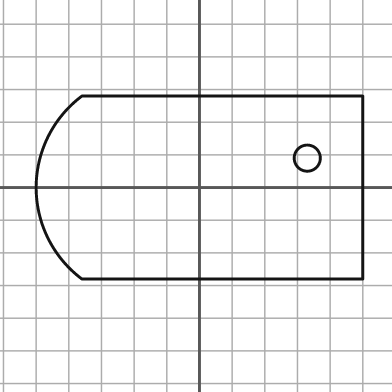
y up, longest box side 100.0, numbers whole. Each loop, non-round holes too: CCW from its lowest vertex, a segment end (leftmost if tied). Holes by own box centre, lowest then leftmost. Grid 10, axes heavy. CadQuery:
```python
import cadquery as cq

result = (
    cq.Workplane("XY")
    .moveTo(-36.0, -28.0)
    .lineTo(50.0, -28.0)
    .lineTo(50.0, 28.0)
    .lineTo(-36.0, 28.0)
    .threePointArc((-50.0, 0.0), (-36.0, -28.0))
    .close()
    .moveTo(33.0, 9.0)
    .circle(4.0)
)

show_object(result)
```